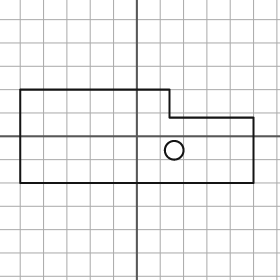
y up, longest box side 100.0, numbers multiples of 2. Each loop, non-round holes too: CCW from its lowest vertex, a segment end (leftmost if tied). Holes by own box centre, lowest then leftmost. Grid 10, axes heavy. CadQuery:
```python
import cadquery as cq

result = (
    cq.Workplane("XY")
    .moveTo(-50.0, -20.0)
    .lineTo(50.0, -20.0)
    .lineTo(50.0, 8.0)
    .lineTo(14.0, 8.0)
    .lineTo(14.0, 20.0)
    .lineTo(-50.0, 20.0)
    .close()
    .moveTo(16.0, -6.0)
    .circle(4.0)
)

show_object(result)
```